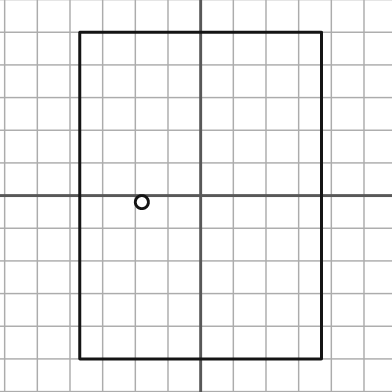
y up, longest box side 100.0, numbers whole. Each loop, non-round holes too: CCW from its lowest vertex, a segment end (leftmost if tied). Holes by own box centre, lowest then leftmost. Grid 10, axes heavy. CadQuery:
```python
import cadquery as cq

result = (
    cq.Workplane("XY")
    .moveTo(-37.0, -50.0)
    .lineTo(37.0, -50.0)
    .lineTo(37.0, 50.0)
    .lineTo(-37.0, 50.0)
    .close()
    .moveTo(-18.0, -2.0)
    .circle(2.0)
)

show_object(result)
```